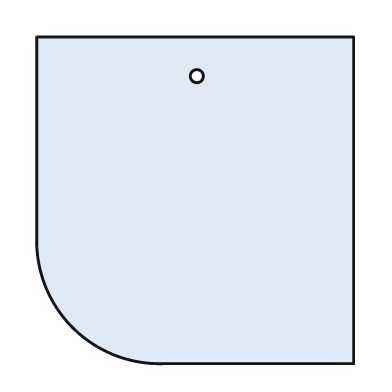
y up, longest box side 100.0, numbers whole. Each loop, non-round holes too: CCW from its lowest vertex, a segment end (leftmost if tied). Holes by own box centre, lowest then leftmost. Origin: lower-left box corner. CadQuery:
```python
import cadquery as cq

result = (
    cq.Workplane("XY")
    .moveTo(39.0, 0.0)
    .lineTo(97.0, 0.0)
    .lineTo(97.0, 100.0)
    .lineTo(0.0, 100.0)
    .lineTo(0.0, 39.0)
    .threePointArc((11.0, 11.0), (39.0, 0.0))
    .close()
    .moveTo(49.0, 88.0)
    .circle(2.0)
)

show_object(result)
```